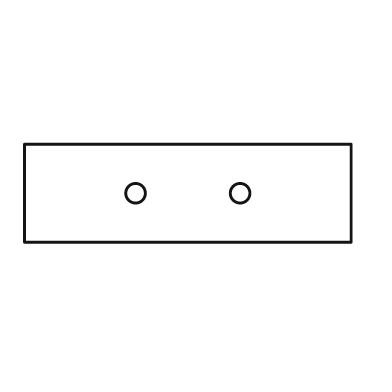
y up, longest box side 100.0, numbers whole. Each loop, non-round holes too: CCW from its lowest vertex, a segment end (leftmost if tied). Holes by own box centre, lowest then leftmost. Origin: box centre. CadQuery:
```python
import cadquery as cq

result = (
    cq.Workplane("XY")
    .moveTo(-50.0, -15.0)
    .lineTo(50.0, -15.0)
    .lineTo(50.0, 15.0)
    .lineTo(-50.0, 15.0)
    .close()
    .moveTo(-16.0, 0.0)
    .circle(3.0)
    .moveTo(16.0, 0.0)
    .circle(3.0)
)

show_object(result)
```